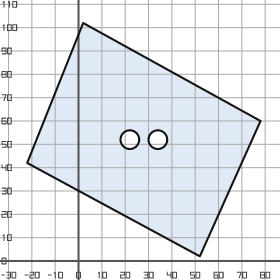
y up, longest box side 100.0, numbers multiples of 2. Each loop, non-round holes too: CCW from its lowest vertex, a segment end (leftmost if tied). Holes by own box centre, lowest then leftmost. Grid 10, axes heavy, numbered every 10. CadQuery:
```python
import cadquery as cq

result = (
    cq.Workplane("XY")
    .moveTo(52.0, 2.0)
    .lineTo(78.0, 60.0)
    .lineTo(2.0, 102.0)
    .lineTo(-22.0, 42.0)
    .close()
    .moveTo(22.0, 52.0)
    .circle(4.0)
    .moveTo(34.0, 52.0)
    .circle(4.0)
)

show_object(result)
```